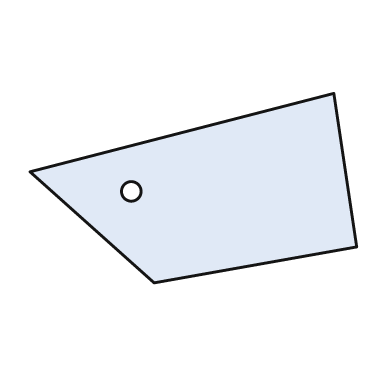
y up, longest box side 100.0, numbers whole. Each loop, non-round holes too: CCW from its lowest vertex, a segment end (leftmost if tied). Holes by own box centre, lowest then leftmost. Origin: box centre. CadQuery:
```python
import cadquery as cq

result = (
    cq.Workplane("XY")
    .moveTo(-12.0, -29.0)
    .lineTo(50.0, -18.0)
    .lineTo(43.0, 29.0)
    .lineTo(-50.0, 5.0)
    .close()
    .moveTo(-19.0, -1.0)
    .circle(3.0)
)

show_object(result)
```